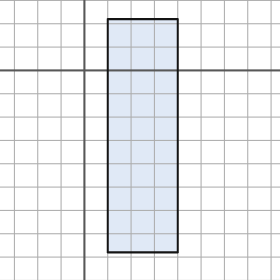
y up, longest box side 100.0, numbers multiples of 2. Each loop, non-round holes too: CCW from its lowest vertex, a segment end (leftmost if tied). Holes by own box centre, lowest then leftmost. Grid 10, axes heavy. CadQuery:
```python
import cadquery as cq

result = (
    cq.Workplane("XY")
    .moveTo(10.0, -78.0)
    .lineTo(40.0, -78.0)
    .lineTo(40.0, 22.0)
    .lineTo(10.0, 22.0)
    .close()
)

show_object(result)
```